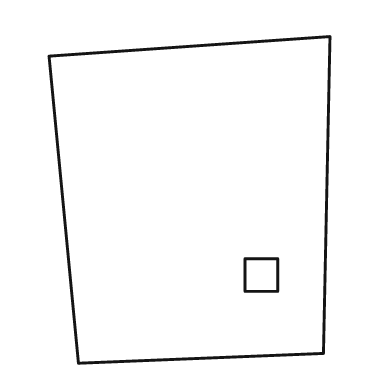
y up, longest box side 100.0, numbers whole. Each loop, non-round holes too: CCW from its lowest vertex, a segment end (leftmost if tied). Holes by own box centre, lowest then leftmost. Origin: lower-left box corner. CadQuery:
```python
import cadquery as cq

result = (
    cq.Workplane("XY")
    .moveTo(9.0, 0.0)
    .lineTo(84.0, 3.0)
    .lineTo(86.0, 100.0)
    .lineTo(0.0, 94.0)
    .close()
    .moveTo(60.0, 22.0)
    .lineTo(70.0, 22.0)
    .lineTo(70.0, 32.0)
    .lineTo(60.0, 32.0)
    .close()
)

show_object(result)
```